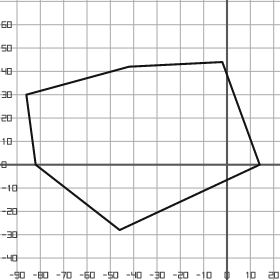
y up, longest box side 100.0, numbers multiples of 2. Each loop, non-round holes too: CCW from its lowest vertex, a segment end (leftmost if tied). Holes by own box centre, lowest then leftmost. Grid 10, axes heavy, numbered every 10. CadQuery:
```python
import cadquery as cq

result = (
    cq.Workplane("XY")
    .moveTo(-46.0, -28.0)
    .lineTo(14.0, 0.0)
    .lineTo(-2.0, 44.0)
    .lineTo(-42.0, 42.0)
    .lineTo(-86.0, 30.0)
    .lineTo(-82.0, 0.0)
    .close()
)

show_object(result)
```